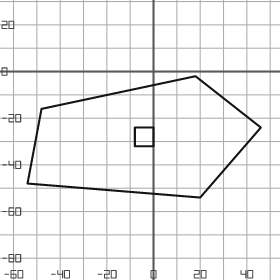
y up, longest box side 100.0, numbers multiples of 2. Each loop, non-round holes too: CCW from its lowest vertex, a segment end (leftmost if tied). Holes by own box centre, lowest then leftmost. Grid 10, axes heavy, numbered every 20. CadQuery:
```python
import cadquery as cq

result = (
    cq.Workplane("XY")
    .moveTo(20.0, -54.0)
    .lineTo(46.0, -24.0)
    .lineTo(18.0, -2.0)
    .lineTo(-48.0, -16.0)
    .lineTo(-54.0, -48.0)
    .close()
    .moveTo(-8.0, -32.0)
    .lineTo(0.0, -32.0)
    .lineTo(0.0, -24.0)
    .lineTo(-8.0, -24.0)
    .close()
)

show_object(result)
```